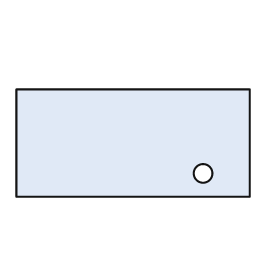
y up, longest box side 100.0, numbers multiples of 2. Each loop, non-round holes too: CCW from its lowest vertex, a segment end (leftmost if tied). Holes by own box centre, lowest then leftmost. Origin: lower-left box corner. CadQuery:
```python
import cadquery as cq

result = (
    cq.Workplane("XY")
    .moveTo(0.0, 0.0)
    .lineTo(100.0, 0.0)
    .lineTo(100.0, 46.0)
    .lineTo(0.0, 46.0)
    .close()
    .moveTo(80.0, 10.0)
    .circle(4.0)
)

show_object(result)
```